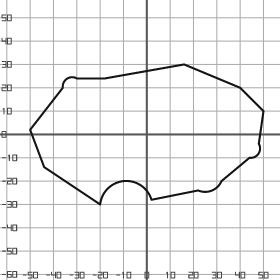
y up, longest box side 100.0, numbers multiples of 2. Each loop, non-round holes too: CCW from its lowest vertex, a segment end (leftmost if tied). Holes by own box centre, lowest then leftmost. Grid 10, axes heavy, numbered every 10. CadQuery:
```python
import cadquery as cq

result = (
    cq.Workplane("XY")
    .moveTo(-20.0, -30.0)
    .threePointArc((-10.0, -20.0), (2.0, -28.0))
    .lineTo(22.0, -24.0)
    .threePointArc((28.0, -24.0), (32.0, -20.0))
    .lineTo(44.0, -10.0)
    .threePointArc((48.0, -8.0), (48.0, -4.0))
    .lineTo(50.0, 10.0)
    .lineTo(40.0, 20.0)
    .lineTo(16.0, 30.0)
    .lineTo(-18.0, 24.0)
    .lineTo(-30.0, 24.0)
    .threePointArc((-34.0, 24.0), (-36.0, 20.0))
    .lineTo(-50.0, 2.0)
    .lineTo(-44.0, -14.0)
    .close()
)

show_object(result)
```